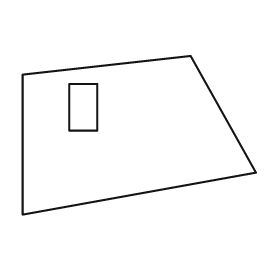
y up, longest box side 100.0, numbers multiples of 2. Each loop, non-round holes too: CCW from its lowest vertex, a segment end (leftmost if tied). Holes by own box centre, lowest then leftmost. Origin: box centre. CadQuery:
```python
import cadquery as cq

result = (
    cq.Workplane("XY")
    .moveTo(-50.0, -34.0)
    .lineTo(50.0, -16.0)
    .lineTo(22.0, 34.0)
    .lineTo(-50.0, 26.0)
    .close()
    .moveTo(-30.0, 2.0)
    .lineTo(-18.0, 2.0)
    .lineTo(-18.0, 22.0)
    .lineTo(-30.0, 22.0)
    .close()
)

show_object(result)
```